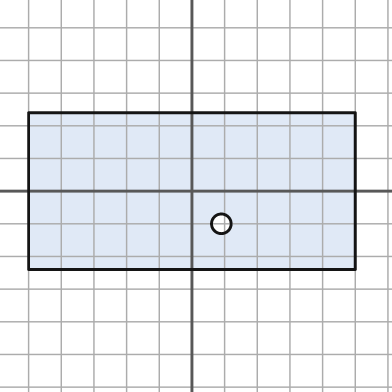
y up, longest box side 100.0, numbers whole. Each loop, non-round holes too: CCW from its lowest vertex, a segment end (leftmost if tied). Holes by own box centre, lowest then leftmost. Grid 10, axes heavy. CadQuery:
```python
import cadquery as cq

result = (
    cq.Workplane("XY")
    .moveTo(-50.0, -24.0)
    .lineTo(50.0, -24.0)
    .lineTo(50.0, 24.0)
    .lineTo(-50.0, 24.0)
    .close()
    .moveTo(9.0, -10.0)
    .circle(3.0)
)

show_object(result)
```